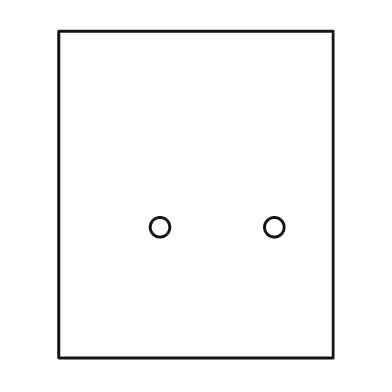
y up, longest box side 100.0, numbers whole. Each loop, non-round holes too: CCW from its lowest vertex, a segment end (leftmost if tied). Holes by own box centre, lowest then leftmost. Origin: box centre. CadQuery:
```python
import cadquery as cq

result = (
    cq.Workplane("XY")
    .moveTo(-42.0, -50.0)
    .lineTo(42.0, -50.0)
    .lineTo(42.0, 50.0)
    .lineTo(-42.0, 50.0)
    .close()
    .moveTo(-11.0, -10.0)
    .circle(3.0)
    .moveTo(24.0, -10.0)
    .circle(3.0)
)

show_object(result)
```